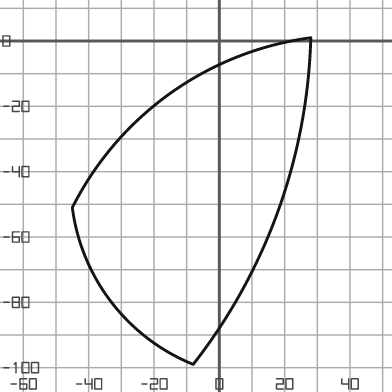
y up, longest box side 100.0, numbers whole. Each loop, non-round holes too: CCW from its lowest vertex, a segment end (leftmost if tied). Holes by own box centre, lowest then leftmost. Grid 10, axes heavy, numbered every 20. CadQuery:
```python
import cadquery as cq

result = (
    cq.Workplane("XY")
    .moveTo(-8.0, -99.0)
    .threePointArc((18.0, -52.0), (28.0, 1.0))
    .threePointArc((-15.0, -16.0), (-45.0, -51.0))
    .threePointArc((-33.0, -80.0), (-8.0, -99.0))
    .close()
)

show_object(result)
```